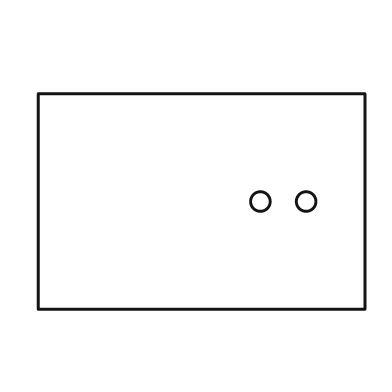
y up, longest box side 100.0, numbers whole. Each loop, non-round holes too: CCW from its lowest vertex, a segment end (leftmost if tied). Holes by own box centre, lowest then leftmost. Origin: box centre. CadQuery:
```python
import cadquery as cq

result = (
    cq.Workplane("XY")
    .moveTo(-50.0, -33.0)
    .lineTo(50.0, -33.0)
    .lineTo(50.0, 33.0)
    .lineTo(-50.0, 33.0)
    .close()
    .moveTo(18.0, 0.0)
    .circle(3.0)
    .moveTo(32.0, 0.0)
    .circle(3.0)
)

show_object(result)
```